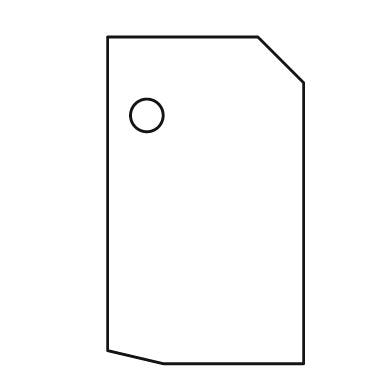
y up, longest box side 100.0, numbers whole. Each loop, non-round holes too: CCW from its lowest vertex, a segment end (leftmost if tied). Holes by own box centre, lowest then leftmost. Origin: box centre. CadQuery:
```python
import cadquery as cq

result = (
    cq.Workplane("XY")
    .moveTo(-13.0, -50.0)
    .lineTo(30.0, -50.0)
    .lineTo(30.0, 36.0)
    .lineTo(16.0, 50.0)
    .lineTo(-30.0, 50.0)
    .lineTo(-30.0, -46.0)
    .close()
    .moveTo(-18.0, 26.0)
    .circle(5.0)
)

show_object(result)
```